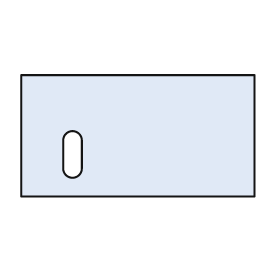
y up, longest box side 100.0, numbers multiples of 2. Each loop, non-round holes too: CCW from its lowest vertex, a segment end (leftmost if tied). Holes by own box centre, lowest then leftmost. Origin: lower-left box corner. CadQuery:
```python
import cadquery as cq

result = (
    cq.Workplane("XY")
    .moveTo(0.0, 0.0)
    .lineTo(100.0, 0.0)
    .lineTo(100.0, 52.0)
    .lineTo(0.0, 52.0)
    .close()
    .moveTo(18.0, 12.0)
    .threePointArc((22.0, 8.0), (26.0, 12.0))
    .lineTo(26.0, 24.0)
    .threePointArc((22.0, 28.0), (18.0, 24.0))
    .close()
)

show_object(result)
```